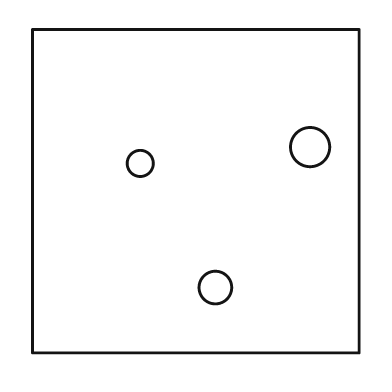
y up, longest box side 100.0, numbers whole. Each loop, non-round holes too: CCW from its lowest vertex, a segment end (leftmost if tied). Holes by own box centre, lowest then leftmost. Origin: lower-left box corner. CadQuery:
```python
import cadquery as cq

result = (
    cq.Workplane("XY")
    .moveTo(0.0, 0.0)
    .lineTo(100.0, 0.0)
    .lineTo(100.0, 99.0)
    .lineTo(0.0, 99.0)
    .close()
    .moveTo(56.0, 20.0)
    .circle(5.0)
    .moveTo(33.0, 58.0)
    .circle(4.0)
    .moveTo(85.0, 63.0)
    .circle(6.0)
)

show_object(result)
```